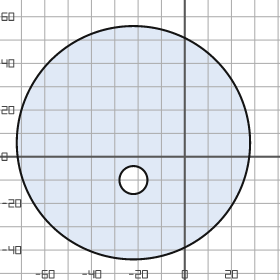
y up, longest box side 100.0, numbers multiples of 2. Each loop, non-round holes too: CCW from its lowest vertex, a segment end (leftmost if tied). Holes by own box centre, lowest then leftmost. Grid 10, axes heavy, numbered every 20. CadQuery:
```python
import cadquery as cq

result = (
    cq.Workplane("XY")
    .moveTo(-22.0, 6.0)
    .circle(50.0)
    .moveTo(-22.0, -10.0)
    .circle(6.0)
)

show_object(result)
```